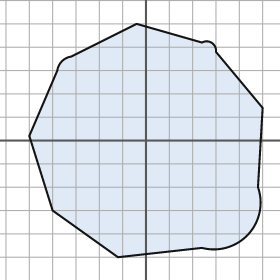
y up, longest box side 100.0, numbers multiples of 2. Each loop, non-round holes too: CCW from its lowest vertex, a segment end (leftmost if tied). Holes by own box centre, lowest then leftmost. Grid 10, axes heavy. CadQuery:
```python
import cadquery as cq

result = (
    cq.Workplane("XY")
    .moveTo(-12.0, -50.0)
    .lineTo(24.0, -46.0)
    .threePointArc((44.0, -40.0), (48.0, -20.0))
    .lineTo(50.0, 14.0)
    .lineTo(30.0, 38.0)
    .threePointArc((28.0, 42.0), (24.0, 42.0))
    .lineTo(-4.0, 50.0)
    .lineTo(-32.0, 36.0)
    .threePointArc((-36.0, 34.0), (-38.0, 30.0))
    .lineTo(-50.0, 2.0)
    .lineTo(-40.0, -30.0)
    .close()
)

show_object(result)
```